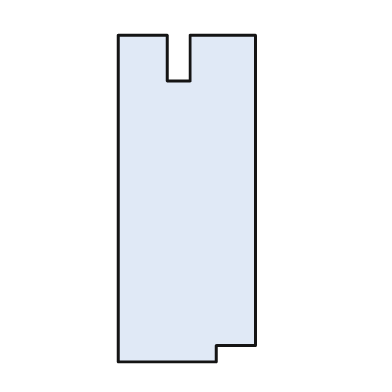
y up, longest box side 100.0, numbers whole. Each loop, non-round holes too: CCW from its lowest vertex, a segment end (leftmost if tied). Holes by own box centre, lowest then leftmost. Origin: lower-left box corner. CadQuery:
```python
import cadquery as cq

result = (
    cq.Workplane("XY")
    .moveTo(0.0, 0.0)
    .lineTo(30.0, 0.0)
    .lineTo(30.0, 5.0)
    .lineTo(42.0, 5.0)
    .lineTo(42.0, 100.0)
    .lineTo(22.0, 100.0)
    .lineTo(22.0, 86.0)
    .lineTo(15.0, 86.0)
    .lineTo(15.0, 100.0)
    .lineTo(0.0, 100.0)
    .close()
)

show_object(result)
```